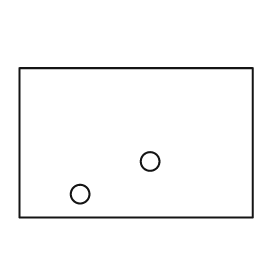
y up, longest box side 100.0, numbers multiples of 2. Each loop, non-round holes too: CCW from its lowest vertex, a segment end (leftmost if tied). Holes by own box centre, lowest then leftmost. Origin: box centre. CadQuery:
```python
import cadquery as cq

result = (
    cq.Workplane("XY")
    .moveTo(-50.0, -32.0)
    .lineTo(50.0, -32.0)
    .lineTo(50.0, 32.0)
    .lineTo(-50.0, 32.0)
    .close()
    .moveTo(-24.0, -22.0)
    .circle(4.0)
    .moveTo(6.0, -8.0)
    .circle(4.0)
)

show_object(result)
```